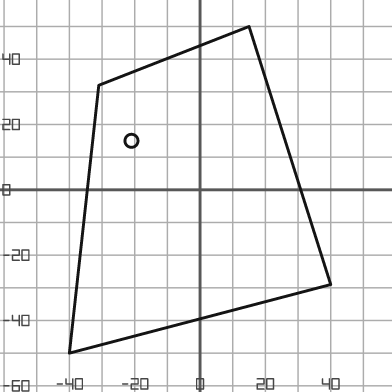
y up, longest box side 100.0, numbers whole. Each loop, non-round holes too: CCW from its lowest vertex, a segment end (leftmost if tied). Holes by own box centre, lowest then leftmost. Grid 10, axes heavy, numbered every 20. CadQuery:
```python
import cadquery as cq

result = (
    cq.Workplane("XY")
    .moveTo(-40.0, -50.0)
    .lineTo(40.0, -29.0)
    .lineTo(15.0, 50.0)
    .lineTo(-31.0, 32.0)
    .close()
    .moveTo(-21.0, 15.0)
    .circle(2.0)
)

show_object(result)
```